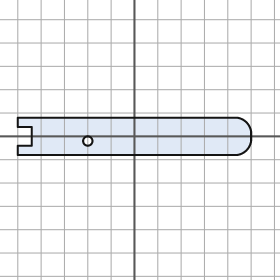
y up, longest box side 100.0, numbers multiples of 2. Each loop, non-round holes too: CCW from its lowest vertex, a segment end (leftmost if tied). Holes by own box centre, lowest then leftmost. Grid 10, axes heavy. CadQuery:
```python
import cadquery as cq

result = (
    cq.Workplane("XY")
    .moveTo(-50.0, -8.0)
    .lineTo(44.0, -8.0)
    .threePointArc((48.0, -6.0), (50.0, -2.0))
    .lineTo(50.0, 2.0)
    .threePointArc((48.0, 6.0), (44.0, 8.0))
    .lineTo(-50.0, 8.0)
    .lineTo(-50.0, 4.0)
    .lineTo(-44.0, 4.0)
    .lineTo(-44.0, -4.0)
    .lineTo(-50.0, -4.0)
    .close()
    .moveTo(-20.0, -2.0)
    .circle(2.0)
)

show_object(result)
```